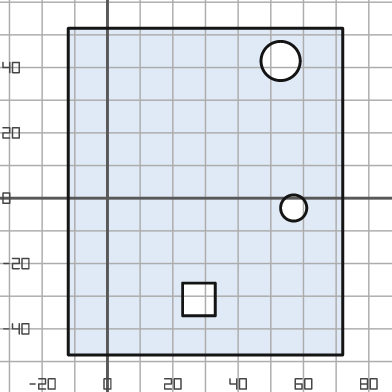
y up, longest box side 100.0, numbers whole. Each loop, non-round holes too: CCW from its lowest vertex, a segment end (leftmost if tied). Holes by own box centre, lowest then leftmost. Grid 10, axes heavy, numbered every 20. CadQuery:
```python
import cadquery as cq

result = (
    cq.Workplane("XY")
    .moveTo(-12.0, -48.0)
    .lineTo(72.0, -48.0)
    .lineTo(72.0, 52.0)
    .lineTo(-12.0, 52.0)
    .close()
    .moveTo(23.0, -36.0)
    .lineTo(33.0, -36.0)
    .lineTo(33.0, -26.0)
    .lineTo(23.0, -26.0)
    .close()
    .moveTo(57.0, -3.0)
    .circle(4.0)
    .moveTo(53.0, 42.0)
    .circle(6.0)
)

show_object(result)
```